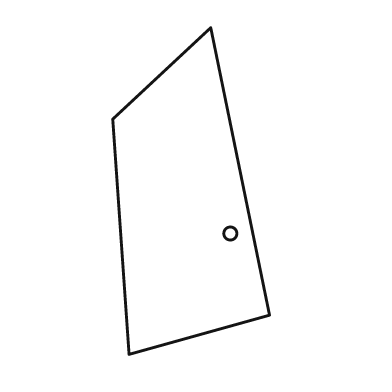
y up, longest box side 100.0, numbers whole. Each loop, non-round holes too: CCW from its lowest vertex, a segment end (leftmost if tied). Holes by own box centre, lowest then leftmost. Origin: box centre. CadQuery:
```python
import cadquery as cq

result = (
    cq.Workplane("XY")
    .moveTo(-19.0, -50.0)
    .lineTo(24.0, -38.0)
    .lineTo(6.0, 50.0)
    .lineTo(-24.0, 22.0)
    .close()
    .moveTo(12.0, -13.0)
    .circle(2.0)
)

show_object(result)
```